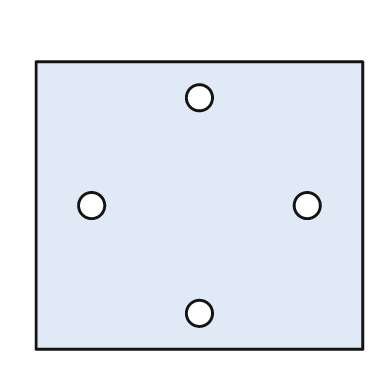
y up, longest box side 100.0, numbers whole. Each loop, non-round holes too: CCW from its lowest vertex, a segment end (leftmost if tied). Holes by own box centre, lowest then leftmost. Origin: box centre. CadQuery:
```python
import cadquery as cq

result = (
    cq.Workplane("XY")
    .moveTo(-50.0, -44.0)
    .lineTo(50.0, -44.0)
    .lineTo(50.0, 44.0)
    .lineTo(-50.0, 44.0)
    .close()
    .moveTo(0.0, -33.0)
    .circle(4.0)
    .moveTo(-33.0, 0.0)
    .circle(4.0)
    .moveTo(33.0, 0.0)
    .circle(4.0)
    .moveTo(0.0, 33.0)
    .circle(4.0)
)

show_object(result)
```